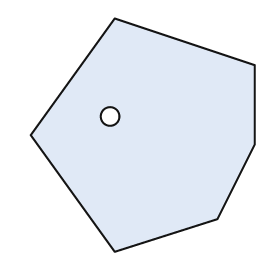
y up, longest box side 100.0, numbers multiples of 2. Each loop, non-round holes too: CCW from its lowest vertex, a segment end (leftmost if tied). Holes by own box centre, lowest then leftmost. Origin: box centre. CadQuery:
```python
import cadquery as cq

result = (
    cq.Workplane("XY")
    .moveTo(-12.0, -50.0)
    .lineTo(32.0, -36.0)
    .lineTo(48.0, -4.0)
    .lineTo(48.0, 30.0)
    .lineTo(-12.0, 50.0)
    .lineTo(-48.0, 0.0)
    .close()
    .moveTo(-14.0, 8.0)
    .circle(4.0)
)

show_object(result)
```